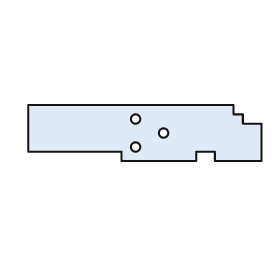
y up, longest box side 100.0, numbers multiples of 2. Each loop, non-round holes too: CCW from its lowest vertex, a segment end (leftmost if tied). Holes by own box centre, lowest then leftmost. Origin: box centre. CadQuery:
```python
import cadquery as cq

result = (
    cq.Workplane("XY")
    .moveTo(-10.0, -12.0)
    .lineTo(22.0, -12.0)
    .lineTo(22.0, -8.0)
    .lineTo(30.0, -8.0)
    .lineTo(30.0, -12.0)
    .lineTo(50.0, -12.0)
    .lineTo(50.0, 4.0)
    .lineTo(42.0, 4.0)
    .lineTo(42.0, 8.0)
    .lineTo(38.0, 8.0)
    .lineTo(38.0, 12.0)
    .lineTo(-50.0, 12.0)
    .lineTo(-50.0, -8.0)
    .lineTo(-10.0, -8.0)
    .close()
    .moveTo(-4.0, -6.0)
    .circle(2.0)
    .moveTo(8.0, 0.0)
    .circle(2.0)
    .moveTo(-4.0, 6.0)
    .circle(2.0)
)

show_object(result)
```